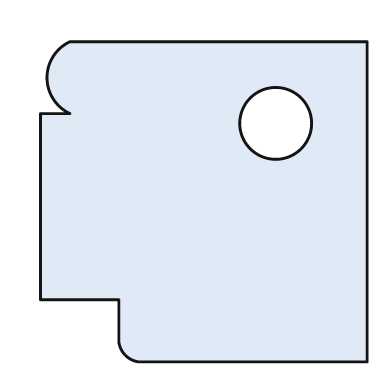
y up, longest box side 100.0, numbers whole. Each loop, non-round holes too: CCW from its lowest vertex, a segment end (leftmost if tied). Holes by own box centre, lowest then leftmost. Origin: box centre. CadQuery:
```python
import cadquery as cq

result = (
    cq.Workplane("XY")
    .moveTo(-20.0, -49.0)
    .lineTo(50.0, -49.0)
    .lineTo(50.0, 49.0)
    .lineTo(-41.0, 49.0)
    .threePointArc((-48.0, 38.0), (-41.0, 27.0))
    .lineTo(-50.0, 27.0)
    .lineTo(-50.0, -30.0)
    .lineTo(-26.0, -30.0)
    .lineTo(-26.0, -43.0)
    .threePointArc((-24.0, -47.0), (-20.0, -49.0))
    .close()
    .moveTo(22.0, 24.0)
    .circle(11.0)
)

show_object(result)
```